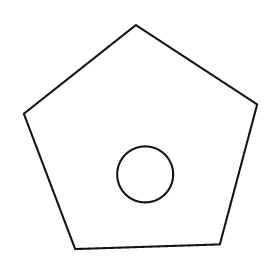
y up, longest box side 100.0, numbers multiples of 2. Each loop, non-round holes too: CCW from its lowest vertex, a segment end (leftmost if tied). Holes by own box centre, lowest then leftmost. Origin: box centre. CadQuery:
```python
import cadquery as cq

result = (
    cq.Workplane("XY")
    .moveTo(-28.0, -48.0)
    .lineTo(34.0, -46.0)
    .lineTo(50.0, 14.0)
    .lineTo(-2.0, 48.0)
    .lineTo(-50.0, 10.0)
    .close()
    .moveTo(2.0, -16.0)
    .circle(12.0)
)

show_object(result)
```